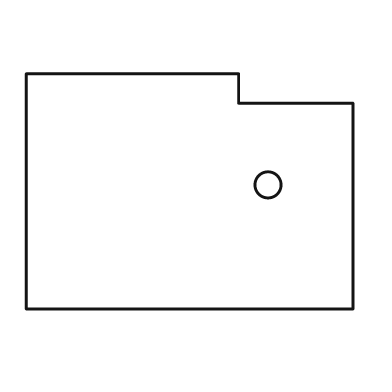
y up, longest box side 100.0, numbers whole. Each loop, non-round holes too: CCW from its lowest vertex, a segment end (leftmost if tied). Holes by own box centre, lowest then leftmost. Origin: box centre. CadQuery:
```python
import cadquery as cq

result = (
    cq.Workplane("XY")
    .moveTo(-50.0, -36.0)
    .lineTo(50.0, -36.0)
    .lineTo(50.0, 27.0)
    .lineTo(15.0, 27.0)
    .lineTo(15.0, 36.0)
    .lineTo(-50.0, 36.0)
    .close()
    .moveTo(24.0, 2.0)
    .circle(4.0)
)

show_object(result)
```